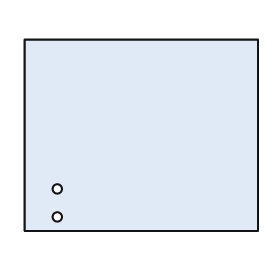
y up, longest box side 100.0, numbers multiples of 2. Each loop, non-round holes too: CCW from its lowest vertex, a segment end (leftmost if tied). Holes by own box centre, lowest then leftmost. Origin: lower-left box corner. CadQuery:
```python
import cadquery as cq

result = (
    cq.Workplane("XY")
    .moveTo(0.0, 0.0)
    .lineTo(100.0, 0.0)
    .lineTo(100.0, 82.0)
    .lineTo(0.0, 82.0)
    .close()
    .moveTo(14.0, 6.0)
    .circle(2.0)
    .moveTo(14.0, 18.0)
    .circle(2.0)
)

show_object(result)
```